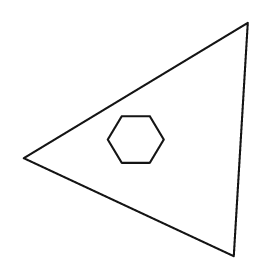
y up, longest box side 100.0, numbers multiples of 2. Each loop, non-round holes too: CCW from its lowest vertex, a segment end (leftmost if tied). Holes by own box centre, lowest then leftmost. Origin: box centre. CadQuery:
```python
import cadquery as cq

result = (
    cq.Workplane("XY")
    .moveTo(42.0, -50.0)
    .lineTo(48.0, 50.0)
    .lineTo(-48.0, -8.0)
    .close()
    .moveTo(-6.0, -10.0)
    .lineTo(6.0, -10.0)
    .lineTo(12.0, 0.0)
    .lineTo(6.0, 10.0)
    .lineTo(-6.0, 10.0)
    .lineTo(-12.0, 0.0)
    .close()
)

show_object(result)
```